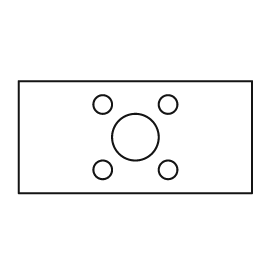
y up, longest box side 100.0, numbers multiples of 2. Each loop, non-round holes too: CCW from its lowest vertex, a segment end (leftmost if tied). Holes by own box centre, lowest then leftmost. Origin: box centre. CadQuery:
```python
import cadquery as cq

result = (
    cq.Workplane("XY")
    .moveTo(-50.0, -24.0)
    .lineTo(50.0, -24.0)
    .lineTo(50.0, 24.0)
    .lineTo(-50.0, 24.0)
    .close()
    .moveTo(-14.0, -14.0)
    .circle(4.0)
    .moveTo(14.0, -14.0)
    .circle(4.0)
    .moveTo(0.0, 0.0)
    .circle(10.0)
    .moveTo(-14.0, 14.0)
    .circle(4.0)
    .moveTo(14.0, 14.0)
    .circle(4.0)
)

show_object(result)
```